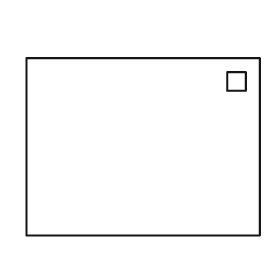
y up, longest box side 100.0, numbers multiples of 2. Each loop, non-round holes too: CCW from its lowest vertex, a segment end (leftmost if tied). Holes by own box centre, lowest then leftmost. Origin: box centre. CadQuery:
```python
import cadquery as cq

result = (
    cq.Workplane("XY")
    .moveTo(-50.0, -38.0)
    .lineTo(50.0, -38.0)
    .lineTo(50.0, 38.0)
    .lineTo(-50.0, 38.0)
    .close()
    .moveTo(36.0, 24.0)
    .lineTo(44.0, 24.0)
    .lineTo(44.0, 32.0)
    .lineTo(36.0, 32.0)
    .close()
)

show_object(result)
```